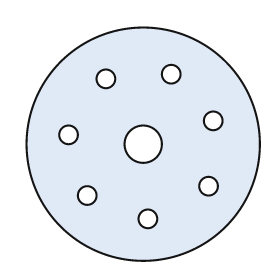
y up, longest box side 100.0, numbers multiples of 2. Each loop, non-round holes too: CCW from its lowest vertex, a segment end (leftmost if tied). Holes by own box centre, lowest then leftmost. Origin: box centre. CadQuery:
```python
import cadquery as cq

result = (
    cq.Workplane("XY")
    .moveTo(0.0, 0.0)
    .circle(50.0)
    .moveTo(2.0, -32.0)
    .circle(4.0)
    .moveTo(-24.0, -22.0)
    .circle(4.0)
    .moveTo(28.0, -18.0)
    .circle(4.0)
    .moveTo(0.0, 0.0)
    .circle(8.0)
    .moveTo(-32.0, 4.0)
    .circle(4.0)
    .moveTo(30.0, 10.0)
    .circle(4.0)
    .moveTo(-16.0, 28.0)
    .circle(4.0)
    .moveTo(12.0, 30.0)
    .circle(4.0)
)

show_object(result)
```